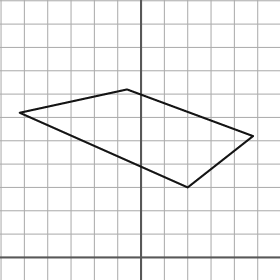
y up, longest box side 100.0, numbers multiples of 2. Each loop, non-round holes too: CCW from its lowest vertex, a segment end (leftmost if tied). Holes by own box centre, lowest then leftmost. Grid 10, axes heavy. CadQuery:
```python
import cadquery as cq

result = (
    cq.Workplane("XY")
    .moveTo(20.0, 30.0)
    .lineTo(48.0, 52.0)
    .lineTo(-6.0, 72.0)
    .lineTo(-52.0, 62.0)
    .close()
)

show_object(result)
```